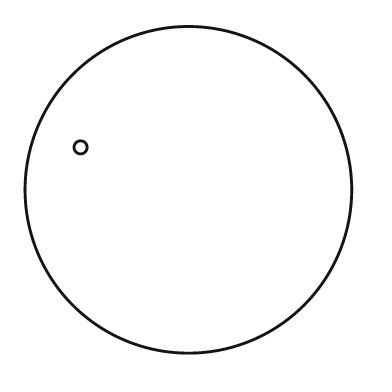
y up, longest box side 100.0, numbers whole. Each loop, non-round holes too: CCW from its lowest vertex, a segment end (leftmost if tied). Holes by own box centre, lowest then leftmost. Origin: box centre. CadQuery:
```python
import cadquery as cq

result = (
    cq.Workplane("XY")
    .moveTo(0.0, 0.0)
    .circle(50.0)
    .moveTo(-33.0, 13.0)
    .circle(2.0)
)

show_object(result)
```